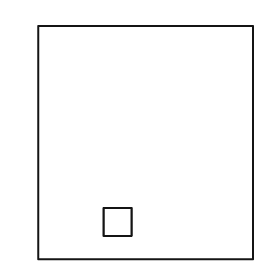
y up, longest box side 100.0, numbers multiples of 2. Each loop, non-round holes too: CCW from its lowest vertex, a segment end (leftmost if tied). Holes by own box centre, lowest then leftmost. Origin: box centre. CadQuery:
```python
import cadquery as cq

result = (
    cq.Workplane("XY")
    .moveTo(-46.0, -50.0)
    .lineTo(46.0, -50.0)
    .lineTo(46.0, 50.0)
    .lineTo(-46.0, 50.0)
    .close()
    .moveTo(-18.0, -40.0)
    .lineTo(-6.0, -40.0)
    .lineTo(-6.0, -28.0)
    .lineTo(-18.0, -28.0)
    .close()
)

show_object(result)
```